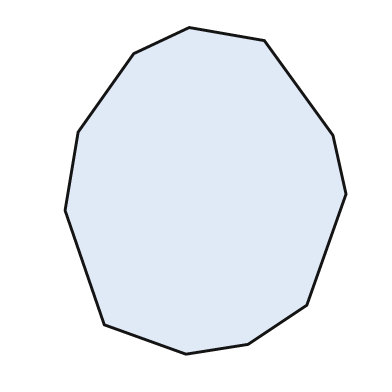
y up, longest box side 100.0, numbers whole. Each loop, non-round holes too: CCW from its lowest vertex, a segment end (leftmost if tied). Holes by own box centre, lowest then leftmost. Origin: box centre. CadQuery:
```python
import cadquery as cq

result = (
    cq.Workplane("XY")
    .moveTo(-6.0, -50.0)
    .lineTo(13.0, -47.0)
    .lineTo(31.0, -35.0)
    .lineTo(43.0, -1.0)
    .lineTo(39.0, 17.0)
    .lineTo(18.0, 46.0)
    .lineTo(-5.0, 50.0)
    .lineTo(-22.0, 42.0)
    .lineTo(-39.0, 18.0)
    .lineTo(-43.0, -6.0)
    .lineTo(-31.0, -41.0)
    .close()
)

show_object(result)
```